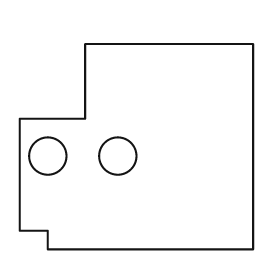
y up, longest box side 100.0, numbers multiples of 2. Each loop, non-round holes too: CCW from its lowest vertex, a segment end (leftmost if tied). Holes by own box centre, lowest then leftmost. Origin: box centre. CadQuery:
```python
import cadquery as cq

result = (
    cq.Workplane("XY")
    .moveTo(-38.0, -44.0)
    .lineTo(50.0, -44.0)
    .lineTo(50.0, 44.0)
    .lineTo(-22.0, 44.0)
    .lineTo(-22.0, 12.0)
    .lineTo(-50.0, 12.0)
    .lineTo(-50.0, -36.0)
    .lineTo(-38.0, -36.0)
    .close()
    .moveTo(-38.0, -4.0)
    .circle(8.0)
    .moveTo(-8.0, -4.0)
    .circle(8.0)
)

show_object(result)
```